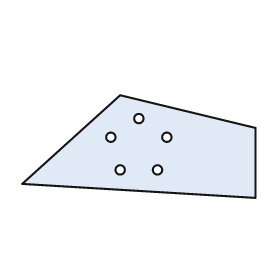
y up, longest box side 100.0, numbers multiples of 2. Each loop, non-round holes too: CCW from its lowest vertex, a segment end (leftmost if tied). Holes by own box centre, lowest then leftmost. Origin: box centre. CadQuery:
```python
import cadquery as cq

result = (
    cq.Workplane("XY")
    .moveTo(50.0, -22.0)
    .lineTo(50.0, 8.0)
    .lineTo(-8.0, 22.0)
    .lineTo(-50.0, -16.0)
    .close()
    .moveTo(-8.0, -10.0)
    .circle(2.0)
    .moveTo(8.0, -10.0)
    .circle(2.0)
    .moveTo(-12.0, 4.0)
    .circle(2.0)
    .moveTo(12.0, 4.0)
    .circle(2.0)
    .moveTo(0.0, 12.0)
    .circle(2.0)
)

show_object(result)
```